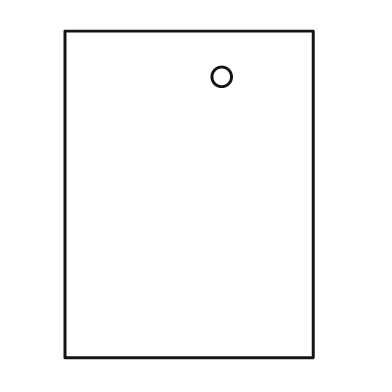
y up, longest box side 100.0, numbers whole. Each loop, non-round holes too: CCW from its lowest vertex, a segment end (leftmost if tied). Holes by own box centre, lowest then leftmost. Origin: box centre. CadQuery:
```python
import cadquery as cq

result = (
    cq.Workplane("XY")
    .moveTo(-38.0, -50.0)
    .lineTo(38.0, -50.0)
    .lineTo(38.0, 50.0)
    .lineTo(-38.0, 50.0)
    .close()
    .moveTo(10.0, 36.0)
    .circle(3.0)
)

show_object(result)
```